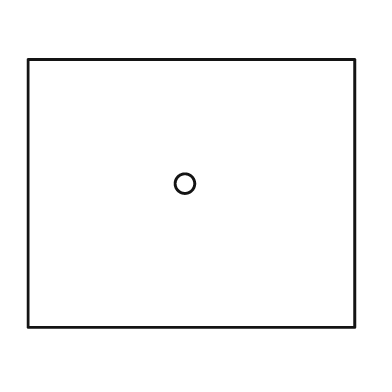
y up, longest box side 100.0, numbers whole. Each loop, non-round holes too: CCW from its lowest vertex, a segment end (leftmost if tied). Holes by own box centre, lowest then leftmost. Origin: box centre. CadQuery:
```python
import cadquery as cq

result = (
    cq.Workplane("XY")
    .moveTo(-50.0, -41.0)
    .lineTo(50.0, -41.0)
    .lineTo(50.0, 41.0)
    .lineTo(-50.0, 41.0)
    .close()
    .moveTo(-2.0, 3.0)
    .circle(3.0)
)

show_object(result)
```